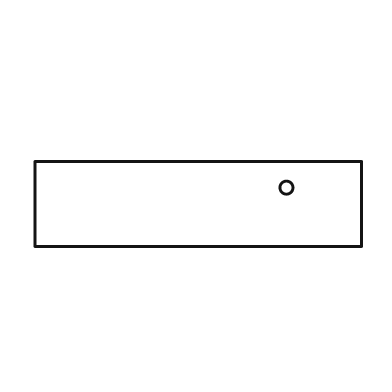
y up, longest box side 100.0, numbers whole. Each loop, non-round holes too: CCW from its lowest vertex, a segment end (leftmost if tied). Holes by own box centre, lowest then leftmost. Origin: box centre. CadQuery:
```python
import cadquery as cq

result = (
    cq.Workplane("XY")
    .moveTo(-50.0, -13.0)
    .lineTo(50.0, -13.0)
    .lineTo(50.0, 13.0)
    .lineTo(-50.0, 13.0)
    .close()
    .moveTo(27.0, 5.0)
    .circle(2.0)
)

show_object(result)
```